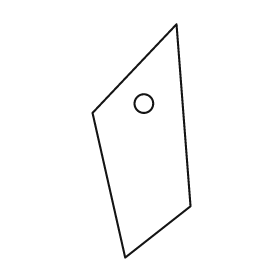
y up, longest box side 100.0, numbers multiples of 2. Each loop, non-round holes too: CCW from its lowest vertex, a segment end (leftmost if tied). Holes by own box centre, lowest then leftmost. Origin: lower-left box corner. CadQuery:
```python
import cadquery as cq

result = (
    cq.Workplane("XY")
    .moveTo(14.0, 0.0)
    .lineTo(42.0, 22.0)
    .lineTo(36.0, 100.0)
    .lineTo(0.0, 62.0)
    .close()
    .moveTo(22.0, 66.0)
    .circle(4.0)
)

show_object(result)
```